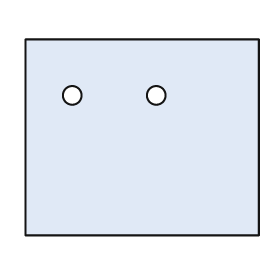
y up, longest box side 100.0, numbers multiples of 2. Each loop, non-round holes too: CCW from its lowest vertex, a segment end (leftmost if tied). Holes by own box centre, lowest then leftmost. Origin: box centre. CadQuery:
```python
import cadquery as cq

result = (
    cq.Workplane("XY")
    .moveTo(-50.0, -42.0)
    .lineTo(50.0, -42.0)
    .lineTo(50.0, 42.0)
    .lineTo(-50.0, 42.0)
    .close()
    .moveTo(-30.0, 18.0)
    .circle(4.0)
    .moveTo(6.0, 18.0)
    .circle(4.0)
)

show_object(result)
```